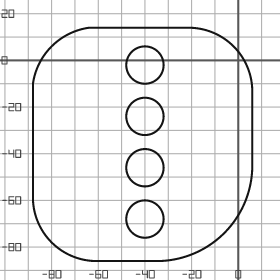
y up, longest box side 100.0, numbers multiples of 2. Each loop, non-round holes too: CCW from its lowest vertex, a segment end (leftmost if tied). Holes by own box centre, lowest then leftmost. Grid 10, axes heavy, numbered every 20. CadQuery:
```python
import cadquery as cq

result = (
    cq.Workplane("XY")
    .moveTo(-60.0, -86.0)
    .lineTo(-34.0, -86.0)
    .threePointArc((-6.0, -74.0), (6.0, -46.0))
    .lineTo(6.0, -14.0)
    .threePointArc((-2.0, 6.0), (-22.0, 14.0))
    .lineTo(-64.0, 14.0)
    .threePointArc((-80.0, 6.0), (-88.0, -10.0))
    .lineTo(-88.0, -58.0)
    .threePointArc((-80.0, -78.0), (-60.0, -86.0))
    .close()
    .moveTo(-40.0, -68.0)
    .circle(8.0)
    .moveTo(-40.0, -46.0)
    .circle(8.0)
    .moveTo(-40.0, -24.0)
    .circle(8.0)
    .moveTo(-40.0, -2.0)
    .circle(8.0)
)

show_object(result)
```